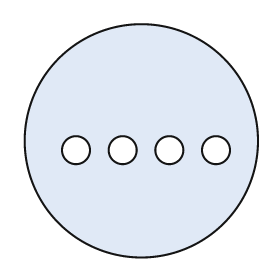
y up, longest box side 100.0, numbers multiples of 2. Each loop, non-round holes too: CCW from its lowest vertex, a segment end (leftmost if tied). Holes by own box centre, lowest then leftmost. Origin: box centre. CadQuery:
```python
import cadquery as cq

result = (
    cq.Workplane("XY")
    .moveTo(0.0, 0.0)
    .circle(50.0)
    .moveTo(-28.0, -4.0)
    .circle(6.0)
    .moveTo(-8.0, -4.0)
    .circle(6.0)
    .moveTo(12.0, -4.0)
    .circle(6.0)
    .moveTo(32.0, -4.0)
    .circle(6.0)
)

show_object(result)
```